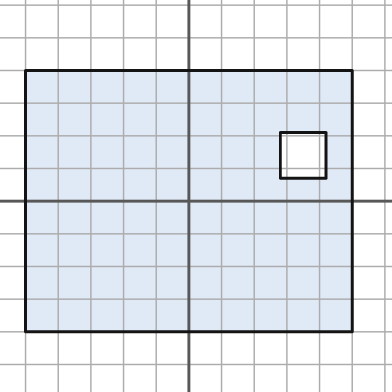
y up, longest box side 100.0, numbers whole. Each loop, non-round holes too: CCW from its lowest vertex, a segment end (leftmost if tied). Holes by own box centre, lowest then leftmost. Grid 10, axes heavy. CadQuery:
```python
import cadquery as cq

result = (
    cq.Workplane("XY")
    .moveTo(-50.0, -40.0)
    .lineTo(50.0, -40.0)
    .lineTo(50.0, 40.0)
    .lineTo(-50.0, 40.0)
    .close()
    .moveTo(28.0, 7.0)
    .lineTo(42.0, 7.0)
    .lineTo(42.0, 21.0)
    .lineTo(28.0, 21.0)
    .close()
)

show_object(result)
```